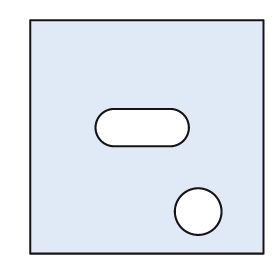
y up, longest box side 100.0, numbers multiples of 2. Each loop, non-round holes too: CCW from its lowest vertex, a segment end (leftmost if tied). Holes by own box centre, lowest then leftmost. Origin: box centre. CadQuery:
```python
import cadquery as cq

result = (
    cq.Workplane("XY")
    .moveTo(-50.0, -50.0)
    .lineTo(50.0, -50.0)
    .lineTo(50.0, 50.0)
    .lineTo(-50.0, 50.0)
    .close()
    .moveTo(22.0, -32.0)
    .circle(10.0)
    .moveTo(-14.0, -4.0)
    .lineTo(10.0, -4.0)
    .threePointArc((18.0, 4.0), (10.0, 12.0))
    .lineTo(-14.0, 12.0)
    .threePointArc((-22.0, 4.0), (-14.0, -4.0))
    .close()
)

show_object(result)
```